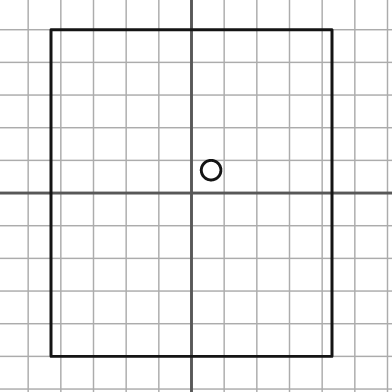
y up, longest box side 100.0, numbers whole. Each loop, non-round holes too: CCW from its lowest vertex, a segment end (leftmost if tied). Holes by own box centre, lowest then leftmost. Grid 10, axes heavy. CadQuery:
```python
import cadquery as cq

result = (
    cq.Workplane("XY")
    .moveTo(-43.0, -50.0)
    .lineTo(43.0, -50.0)
    .lineTo(43.0, 50.0)
    .lineTo(-43.0, 50.0)
    .close()
    .moveTo(6.0, 7.0)
    .circle(3.0)
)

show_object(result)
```